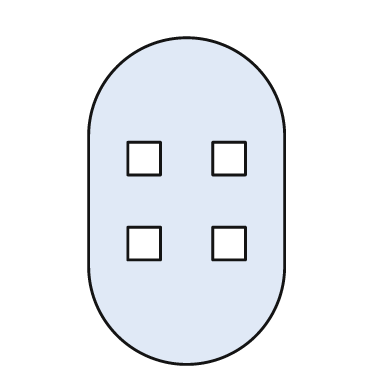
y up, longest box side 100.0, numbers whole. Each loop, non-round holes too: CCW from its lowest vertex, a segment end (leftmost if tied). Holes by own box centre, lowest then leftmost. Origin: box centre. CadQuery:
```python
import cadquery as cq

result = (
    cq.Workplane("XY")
    .moveTo(-30.0, -20.0)
    .threePointArc((0.0, -50.0), (30.0, -20.0))
    .lineTo(30.0, 20.0)
    .threePointArc((0.0, 50.0), (-30.0, 20.0))
    .close()
    .moveTo(-18.0, -18.0)
    .lineTo(-8.0, -18.0)
    .lineTo(-8.0, -8.0)
    .lineTo(-18.0, -8.0)
    .close()
    .moveTo(8.0, -18.0)
    .lineTo(18.0, -18.0)
    .lineTo(18.0, -8.0)
    .lineTo(8.0, -8.0)
    .close()
    .moveTo(-18.0, 8.0)
    .lineTo(-8.0, 8.0)
    .lineTo(-8.0, 18.0)
    .lineTo(-18.0, 18.0)
    .close()
    .moveTo(8.0, 8.0)
    .lineTo(18.0, 8.0)
    .lineTo(18.0, 18.0)
    .lineTo(8.0, 18.0)
    .close()
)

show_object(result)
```